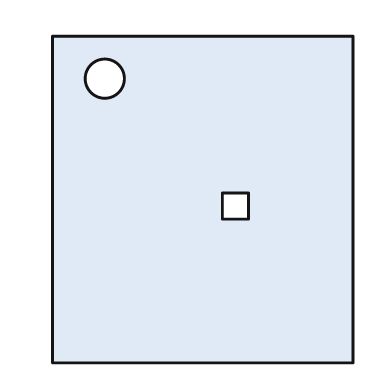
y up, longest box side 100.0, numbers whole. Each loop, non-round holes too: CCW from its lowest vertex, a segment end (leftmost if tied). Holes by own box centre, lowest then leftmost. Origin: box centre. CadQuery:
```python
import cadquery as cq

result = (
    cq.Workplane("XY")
    .moveTo(-46.0, -50.0)
    .lineTo(46.0, -50.0)
    .lineTo(46.0, 50.0)
    .lineTo(-46.0, 50.0)
    .close()
    .moveTo(6.0, -6.0)
    .lineTo(14.0, -6.0)
    .lineTo(14.0, 2.0)
    .lineTo(6.0, 2.0)
    .close()
    .moveTo(-30.0, 37.0)
    .circle(6.0)
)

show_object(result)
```